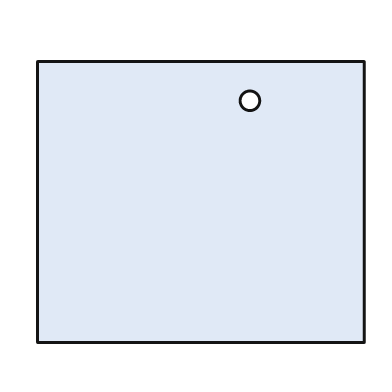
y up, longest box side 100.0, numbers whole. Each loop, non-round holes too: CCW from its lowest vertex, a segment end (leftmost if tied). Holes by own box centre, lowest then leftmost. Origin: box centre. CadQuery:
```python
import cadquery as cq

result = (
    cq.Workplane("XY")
    .moveTo(-50.0, -43.0)
    .lineTo(50.0, -43.0)
    .lineTo(50.0, 43.0)
    .lineTo(-50.0, 43.0)
    .close()
    .moveTo(15.0, 31.0)
    .circle(3.0)
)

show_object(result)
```